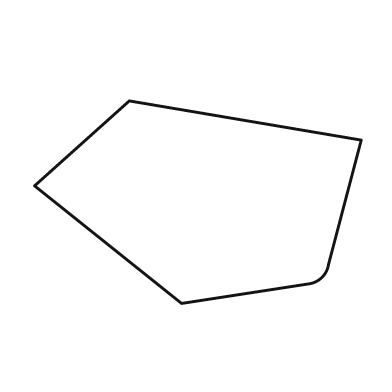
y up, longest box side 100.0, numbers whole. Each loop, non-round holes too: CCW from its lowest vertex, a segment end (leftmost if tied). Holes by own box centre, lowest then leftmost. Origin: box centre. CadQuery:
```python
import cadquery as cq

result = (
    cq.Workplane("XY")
    .moveTo(-5.0, -31.0)
    .lineTo(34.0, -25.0)
    .threePointArc((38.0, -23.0), (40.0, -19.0))
    .lineTo(50.0, 19.0)
    .lineTo(-21.0, 31.0)
    .lineTo(-50.0, 5.0)
    .close()
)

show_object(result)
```